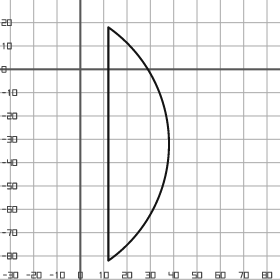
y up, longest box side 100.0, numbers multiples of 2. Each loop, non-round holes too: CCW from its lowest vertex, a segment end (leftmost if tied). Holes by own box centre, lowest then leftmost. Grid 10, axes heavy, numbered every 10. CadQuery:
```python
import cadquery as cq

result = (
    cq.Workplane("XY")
    .moveTo(12.0, -82.0)
    .threePointArc((38.0, -32.0), (12.0, 18.0))
    .close()
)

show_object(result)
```